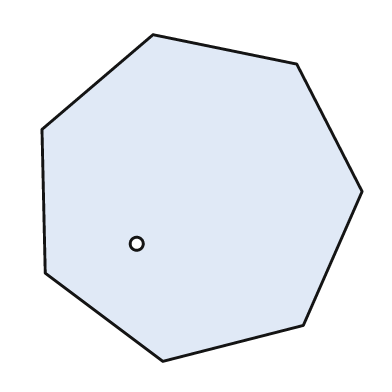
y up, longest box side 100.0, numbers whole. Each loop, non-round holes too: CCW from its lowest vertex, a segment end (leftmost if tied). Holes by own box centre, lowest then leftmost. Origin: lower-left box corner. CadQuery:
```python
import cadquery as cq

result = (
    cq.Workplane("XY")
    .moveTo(37.0, 0.0)
    .lineTo(80.0, 11.0)
    .lineTo(98.0, 52.0)
    .lineTo(78.0, 91.0)
    .lineTo(34.0, 100.0)
    .lineTo(0.0, 71.0)
    .lineTo(1.0, 27.0)
    .close()
    .moveTo(29.0, 36.0)
    .circle(2.0)
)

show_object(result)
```